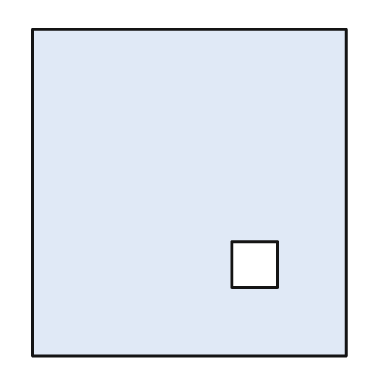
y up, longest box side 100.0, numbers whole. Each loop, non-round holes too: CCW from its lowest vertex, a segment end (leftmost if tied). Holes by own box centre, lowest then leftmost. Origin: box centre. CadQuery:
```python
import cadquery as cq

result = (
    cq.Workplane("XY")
    .moveTo(-48.0, -50.0)
    .lineTo(48.0, -50.0)
    .lineTo(48.0, 50.0)
    .lineTo(-48.0, 50.0)
    .close()
    .moveTo(13.0, -29.0)
    .lineTo(27.0, -29.0)
    .lineTo(27.0, -15.0)
    .lineTo(13.0, -15.0)
    .close()
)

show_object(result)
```